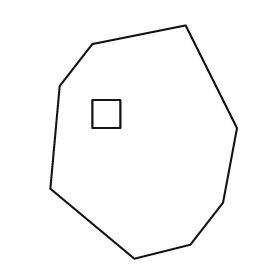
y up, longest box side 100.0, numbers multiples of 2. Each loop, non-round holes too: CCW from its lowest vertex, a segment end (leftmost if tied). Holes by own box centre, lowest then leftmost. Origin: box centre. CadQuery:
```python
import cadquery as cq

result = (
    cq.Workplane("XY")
    .moveTo(-4.0, -50.0)
    .lineTo(20.0, -44.0)
    .lineTo(34.0, -26.0)
    .lineTo(40.0, 6.0)
    .lineTo(18.0, 50.0)
    .lineTo(-22.0, 42.0)
    .lineTo(-36.0, 24.0)
    .lineTo(-40.0, -20.0)
    .close()
    .moveTo(-22.0, 6.0)
    .lineTo(-10.0, 6.0)
    .lineTo(-10.0, 18.0)
    .lineTo(-22.0, 18.0)
    .close()
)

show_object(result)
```